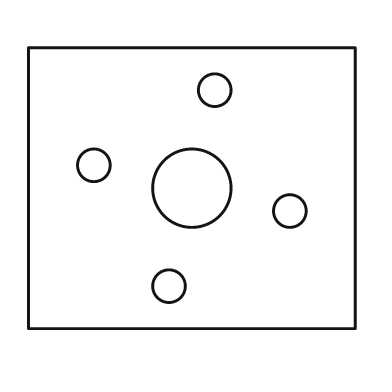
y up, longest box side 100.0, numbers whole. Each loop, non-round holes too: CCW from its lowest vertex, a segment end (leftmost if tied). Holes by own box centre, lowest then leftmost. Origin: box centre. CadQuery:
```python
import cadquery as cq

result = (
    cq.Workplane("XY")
    .moveTo(-50.0, -43.0)
    .lineTo(50.0, -43.0)
    .lineTo(50.0, 43.0)
    .lineTo(-50.0, 43.0)
    .close()
    .moveTo(-7.0, -30.0)
    .circle(5.0)
    .moveTo(30.0, -7.0)
    .circle(5.0)
    .moveTo(0.0, 0.0)
    .circle(12.0)
    .moveTo(-30.0, 7.0)
    .circle(5.0)
    .moveTo(7.0, 30.0)
    .circle(5.0)
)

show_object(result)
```